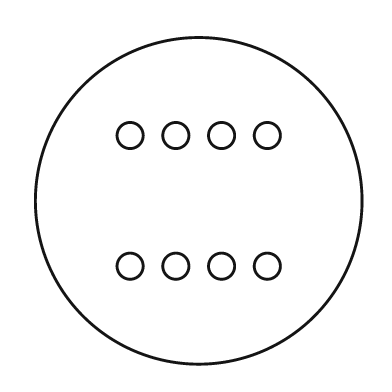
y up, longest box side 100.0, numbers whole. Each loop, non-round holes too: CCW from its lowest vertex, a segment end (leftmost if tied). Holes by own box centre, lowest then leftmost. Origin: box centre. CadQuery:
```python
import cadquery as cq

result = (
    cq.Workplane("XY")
    .moveTo(0.0, 0.0)
    .circle(50.0)
    .moveTo(-21.0, -20.0)
    .circle(4.0)
    .moveTo(-7.0, -20.0)
    .circle(4.0)
    .moveTo(7.0, -20.0)
    .circle(4.0)
    .moveTo(21.0, -20.0)
    .circle(4.0)
    .moveTo(-21.0, 20.0)
    .circle(4.0)
    .moveTo(-7.0, 20.0)
    .circle(4.0)
    .moveTo(7.0, 20.0)
    .circle(4.0)
    .moveTo(21.0, 20.0)
    .circle(4.0)
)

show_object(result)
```